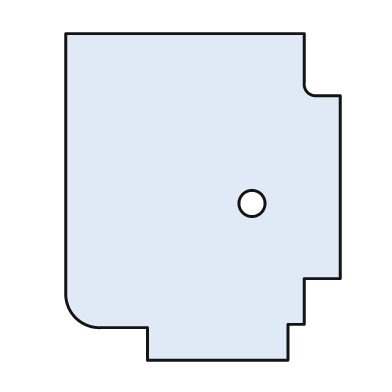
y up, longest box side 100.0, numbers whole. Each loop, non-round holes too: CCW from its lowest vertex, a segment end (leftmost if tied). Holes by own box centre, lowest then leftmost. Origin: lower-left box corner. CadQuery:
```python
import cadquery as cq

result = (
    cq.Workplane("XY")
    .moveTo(25.0, 0.0)
    .lineTo(68.0, 0.0)
    .lineTo(68.0, 11.0)
    .lineTo(73.0, 11.0)
    .lineTo(73.0, 25.0)
    .lineTo(84.0, 25.0)
    .lineTo(84.0, 81.0)
    .lineTo(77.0, 81.0)
    .threePointArc((74.0, 82.0), (73.0, 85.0))
    .lineTo(73.0, 100.0)
    .lineTo(0.0, 100.0)
    .lineTo(0.0, 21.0)
    .threePointArc((3.0, 13.0), (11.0, 10.0))
    .lineTo(25.0, 10.0)
    .close()
    .moveTo(57.0, 48.0)
    .circle(4.0)
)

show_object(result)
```